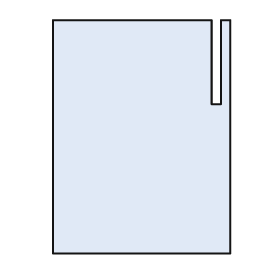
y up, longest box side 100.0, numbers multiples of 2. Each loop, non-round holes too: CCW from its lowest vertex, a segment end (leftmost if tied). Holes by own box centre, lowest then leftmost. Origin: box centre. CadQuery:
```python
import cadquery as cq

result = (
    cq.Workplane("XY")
    .moveTo(-38.0, -50.0)
    .lineTo(38.0, -50.0)
    .lineTo(38.0, 50.0)
    .lineTo(34.0, 50.0)
    .lineTo(34.0, 14.0)
    .lineTo(30.0, 14.0)
    .lineTo(30.0, 50.0)
    .lineTo(-38.0, 50.0)
    .close()
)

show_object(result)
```